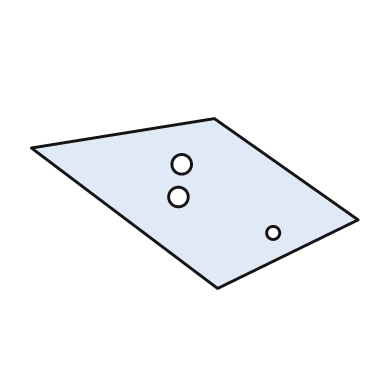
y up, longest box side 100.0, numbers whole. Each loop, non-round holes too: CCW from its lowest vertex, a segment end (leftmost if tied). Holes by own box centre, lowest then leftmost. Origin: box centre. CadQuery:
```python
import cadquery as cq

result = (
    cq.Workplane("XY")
    .moveTo(7.0, -26.0)
    .lineTo(50.0, -5.0)
    .lineTo(6.0, 26.0)
    .lineTo(-50.0, 17.0)
    .close()
    .moveTo(24.0, -9.0)
    .circle(2.0)
    .moveTo(-5.0, 2.0)
    .circle(3.0)
    .moveTo(-4.0, 12.0)
    .circle(3.0)
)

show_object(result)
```